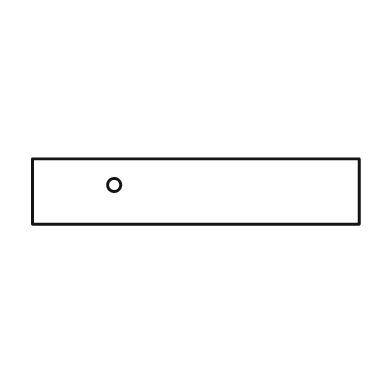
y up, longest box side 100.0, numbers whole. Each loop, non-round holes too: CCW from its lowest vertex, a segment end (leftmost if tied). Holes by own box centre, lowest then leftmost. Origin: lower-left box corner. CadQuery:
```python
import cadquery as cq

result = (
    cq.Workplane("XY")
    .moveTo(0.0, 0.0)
    .lineTo(100.0, 0.0)
    .lineTo(100.0, 20.0)
    .lineTo(0.0, 20.0)
    .close()
    .moveTo(25.0, 12.0)
    .circle(2.0)
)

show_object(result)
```